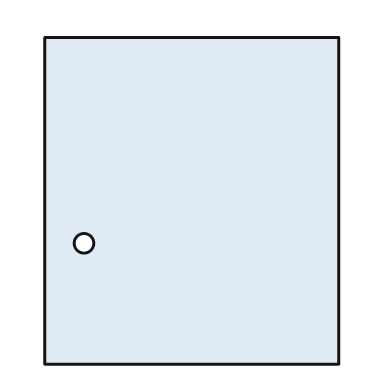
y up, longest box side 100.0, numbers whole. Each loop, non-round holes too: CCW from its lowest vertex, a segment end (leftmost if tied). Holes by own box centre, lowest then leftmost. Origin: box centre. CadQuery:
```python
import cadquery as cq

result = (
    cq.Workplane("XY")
    .moveTo(-45.0, -50.0)
    .lineTo(45.0, -50.0)
    .lineTo(45.0, 50.0)
    .lineTo(-45.0, 50.0)
    .close()
    .moveTo(-33.0, -13.0)
    .circle(3.0)
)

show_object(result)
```